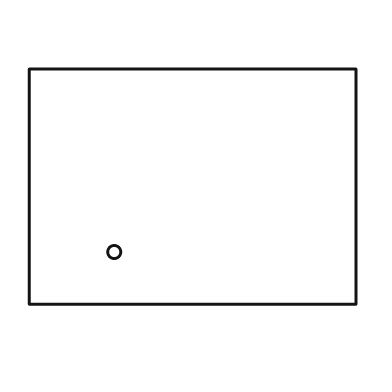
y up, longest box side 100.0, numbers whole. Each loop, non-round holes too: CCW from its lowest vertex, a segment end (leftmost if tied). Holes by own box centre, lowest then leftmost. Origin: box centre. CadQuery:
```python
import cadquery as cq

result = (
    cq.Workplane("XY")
    .moveTo(-50.0, -36.0)
    .lineTo(50.0, -36.0)
    .lineTo(50.0, 36.0)
    .lineTo(-50.0, 36.0)
    .close()
    .moveTo(-24.0, -20.0)
    .circle(2.0)
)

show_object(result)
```